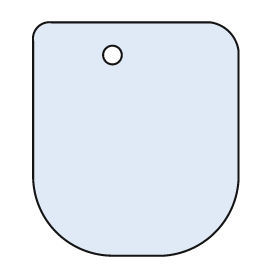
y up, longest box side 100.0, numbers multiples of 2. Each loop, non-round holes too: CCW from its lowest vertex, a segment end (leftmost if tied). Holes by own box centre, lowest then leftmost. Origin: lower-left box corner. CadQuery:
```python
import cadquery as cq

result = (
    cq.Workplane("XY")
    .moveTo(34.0, 0.0)
    .lineTo(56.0, 0.0)
    .threePointArc((78.0, 10.0), (88.0, 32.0))
    .lineTo(88.0, 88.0)
    .threePointArc((84.0, 96.0), (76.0, 100.0))
    .lineTo(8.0, 100.0)
    .threePointArc((2.0, 98.0), (0.0, 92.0))
    .lineTo(0.0, 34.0)
    .threePointArc((10.0, 10.0), (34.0, 0.0))
    .close()
    .moveTo(34.0, 86.0)
    .circle(4.0)
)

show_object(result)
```